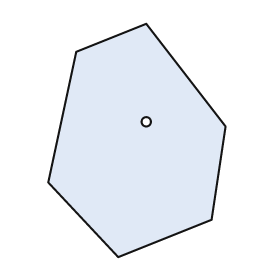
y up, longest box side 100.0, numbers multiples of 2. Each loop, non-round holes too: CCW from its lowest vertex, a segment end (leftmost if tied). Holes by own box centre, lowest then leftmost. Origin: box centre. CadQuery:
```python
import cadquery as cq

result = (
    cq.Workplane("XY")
    .moveTo(-8.0, -50.0)
    .lineTo(32.0, -34.0)
    .lineTo(38.0, 6.0)
    .lineTo(4.0, 50.0)
    .lineTo(-26.0, 38.0)
    .lineTo(-38.0, -18.0)
    .close()
    .moveTo(4.0, 8.0)
    .circle(2.0)
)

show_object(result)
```